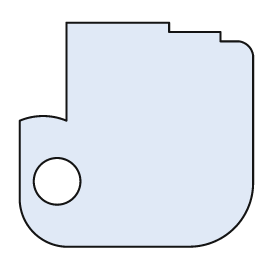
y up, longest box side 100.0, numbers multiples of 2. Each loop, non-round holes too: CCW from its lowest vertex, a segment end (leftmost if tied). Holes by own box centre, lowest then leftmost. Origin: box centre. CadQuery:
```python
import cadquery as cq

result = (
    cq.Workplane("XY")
    .moveTo(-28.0, -48.0)
    .lineTo(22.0, -48.0)
    .threePointArc((42.0, -40.0), (50.0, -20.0))
    .lineTo(50.0, 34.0)
    .threePointArc((48.0, 38.0), (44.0, 40.0))
    .lineTo(36.0, 40.0)
    .lineTo(36.0, 44.0)
    .lineTo(14.0, 44.0)
    .lineTo(14.0, 48.0)
    .lineTo(-30.0, 48.0)
    .lineTo(-30.0, 6.0)
    .threePointArc((-40.0, 8.0), (-50.0, 6.0))
    .lineTo(-50.0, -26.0)
    .threePointArc((-44.0, -42.0), (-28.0, -48.0))
    .close()
    .moveTo(-34.0, -20.0)
    .circle(10.0)
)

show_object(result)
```